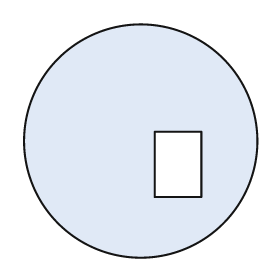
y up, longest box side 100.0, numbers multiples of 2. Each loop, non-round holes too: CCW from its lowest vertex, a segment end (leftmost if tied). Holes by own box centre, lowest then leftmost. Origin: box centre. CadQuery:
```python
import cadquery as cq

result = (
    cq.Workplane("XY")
    .moveTo(0.0, 0.0)
    .circle(50.0)
    .moveTo(6.0, -24.0)
    .lineTo(26.0, -24.0)
    .lineTo(26.0, 4.0)
    .lineTo(6.0, 4.0)
    .close()
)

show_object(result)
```